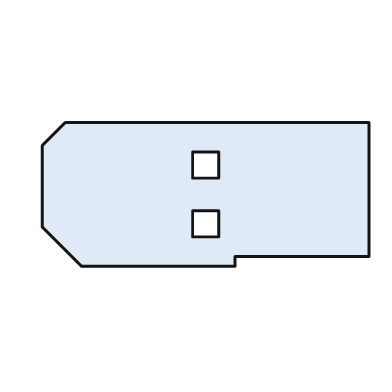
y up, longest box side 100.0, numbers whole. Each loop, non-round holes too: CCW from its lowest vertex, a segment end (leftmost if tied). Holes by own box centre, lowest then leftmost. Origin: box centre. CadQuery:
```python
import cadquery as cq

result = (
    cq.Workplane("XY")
    .moveTo(-38.0, -22.0)
    .lineTo(9.0, -22.0)
    .lineTo(9.0, -19.0)
    .lineTo(50.0, -19.0)
    .lineTo(50.0, 22.0)
    .lineTo(-43.0, 22.0)
    .lineTo(-50.0, 15.0)
    .lineTo(-50.0, -10.0)
    .close()
    .moveTo(-4.0, -13.0)
    .lineTo(4.0, -13.0)
    .lineTo(4.0, -5.0)
    .lineTo(-4.0, -5.0)
    .close()
    .moveTo(-4.0, 5.0)
    .lineTo(4.0, 5.0)
    .lineTo(4.0, 13.0)
    .lineTo(-4.0, 13.0)
    .close()
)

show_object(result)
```